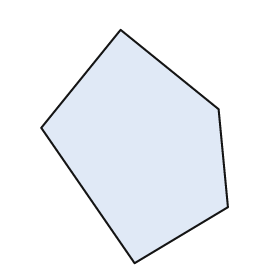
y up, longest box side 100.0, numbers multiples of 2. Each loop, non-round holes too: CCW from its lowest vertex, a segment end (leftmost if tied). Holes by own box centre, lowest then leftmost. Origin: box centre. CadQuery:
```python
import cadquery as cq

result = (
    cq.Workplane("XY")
    .moveTo(0.0, -50.0)
    .lineTo(40.0, -26.0)
    .lineTo(36.0, 16.0)
    .lineTo(-6.0, 50.0)
    .lineTo(-40.0, 8.0)
    .close()
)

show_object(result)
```